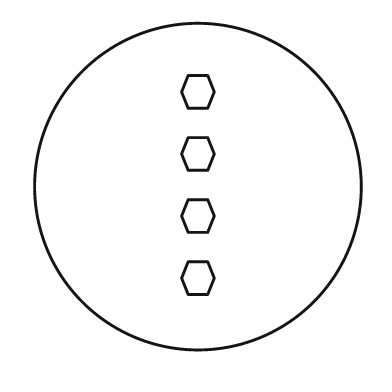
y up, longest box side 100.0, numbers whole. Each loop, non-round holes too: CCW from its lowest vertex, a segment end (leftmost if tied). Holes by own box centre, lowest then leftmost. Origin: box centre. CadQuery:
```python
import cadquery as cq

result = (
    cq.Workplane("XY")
    .moveTo(0.0, 0.0)
    .circle(50.0)
    .moveTo(-3.0, -33.0)
    .lineTo(3.0, -33.0)
    .lineTo(5.0, -28.0)
    .lineTo(3.0, -23.0)
    .lineTo(-3.0, -23.0)
    .lineTo(-5.0, -28.0)
    .close()
    .moveTo(-3.0, -14.0)
    .lineTo(3.0, -14.0)
    .lineTo(5.0, -9.0)
    .lineTo(3.0, -4.0)
    .lineTo(-3.0, -4.0)
    .lineTo(-5.0, -9.0)
    .close()
    .moveTo(-3.0, 5.0)
    .lineTo(3.0, 5.0)
    .lineTo(5.0, 10.0)
    .lineTo(3.0, 15.0)
    .lineTo(-3.0, 15.0)
    .lineTo(-5.0, 10.0)
    .close()
    .moveTo(-3.0, 24.0)
    .lineTo(3.0, 24.0)
    .lineTo(5.0, 29.0)
    .lineTo(3.0, 34.0)
    .lineTo(-3.0, 34.0)
    .lineTo(-5.0, 29.0)
    .close()
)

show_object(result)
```